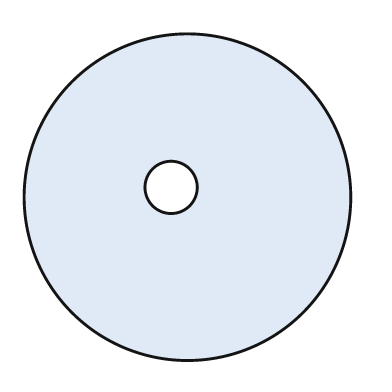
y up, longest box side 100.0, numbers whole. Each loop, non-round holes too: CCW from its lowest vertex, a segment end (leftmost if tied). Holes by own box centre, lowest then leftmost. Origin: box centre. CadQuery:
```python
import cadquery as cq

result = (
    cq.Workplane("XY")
    .moveTo(0.0, 0.0)
    .circle(50.0)
    .moveTo(-5.0, 3.0)
    .circle(8.0)
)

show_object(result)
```